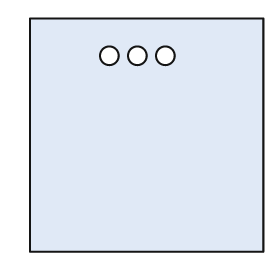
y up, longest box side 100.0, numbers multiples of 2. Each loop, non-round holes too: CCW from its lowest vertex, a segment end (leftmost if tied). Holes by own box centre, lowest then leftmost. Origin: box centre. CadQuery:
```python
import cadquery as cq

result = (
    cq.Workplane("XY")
    .moveTo(-50.0, -50.0)
    .lineTo(50.0, -50.0)
    .lineTo(50.0, 50.0)
    .lineTo(-50.0, 50.0)
    .close()
    .moveTo(-16.0, 34.0)
    .circle(4.0)
    .moveTo(-4.0, 34.0)
    .circle(4.0)
    .moveTo(8.0, 34.0)
    .circle(4.0)
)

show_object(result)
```